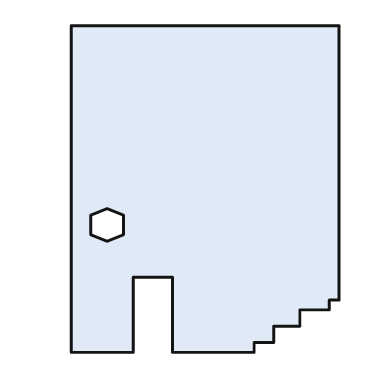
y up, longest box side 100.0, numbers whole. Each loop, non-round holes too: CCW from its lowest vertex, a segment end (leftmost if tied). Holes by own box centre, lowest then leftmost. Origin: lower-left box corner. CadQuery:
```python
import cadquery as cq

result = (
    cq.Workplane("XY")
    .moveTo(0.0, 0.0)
    .lineTo(19.0, 0.0)
    .lineTo(19.0, 23.0)
    .lineTo(31.0, 23.0)
    .lineTo(31.0, 0.0)
    .lineTo(56.0, 0.0)
    .lineTo(56.0, 3.0)
    .lineTo(62.0, 3.0)
    .lineTo(62.0, 8.0)
    .lineTo(70.0, 8.0)
    .lineTo(70.0, 13.0)
    .lineTo(79.0, 13.0)
    .lineTo(79.0, 16.0)
    .lineTo(82.0, 16.0)
    .lineTo(82.0, 100.0)
    .lineTo(0.0, 100.0)
    .close()
    .moveTo(11.0, 34.0)
    .lineTo(16.0, 36.0)
    .lineTo(16.0, 42.0)
    .lineTo(11.0, 44.0)
    .lineTo(6.0, 42.0)
    .lineTo(6.0, 36.0)
    .close()
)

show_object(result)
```